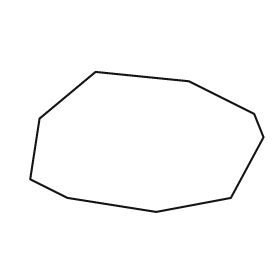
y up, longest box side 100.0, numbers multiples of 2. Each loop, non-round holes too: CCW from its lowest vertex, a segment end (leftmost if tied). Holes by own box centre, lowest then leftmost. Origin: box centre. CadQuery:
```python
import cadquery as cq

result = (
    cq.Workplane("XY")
    .moveTo(4.0, -30.0)
    .lineTo(36.0, -24.0)
    .lineTo(50.0, 2.0)
    .lineTo(46.0, 12.0)
    .lineTo(18.0, 26.0)
    .lineTo(-22.0, 30.0)
    .lineTo(-46.0, 10.0)
    .lineTo(-50.0, -16.0)
    .lineTo(-34.0, -24.0)
    .close()
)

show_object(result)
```